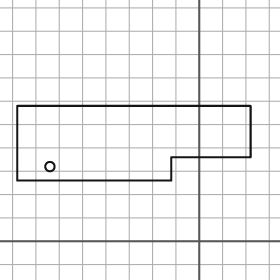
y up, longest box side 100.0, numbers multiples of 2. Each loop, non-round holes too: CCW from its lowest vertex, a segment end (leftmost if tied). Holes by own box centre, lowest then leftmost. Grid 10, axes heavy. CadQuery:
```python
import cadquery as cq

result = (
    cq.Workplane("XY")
    .moveTo(-78.0, 26.0)
    .lineTo(-12.0, 26.0)
    .lineTo(-12.0, 36.0)
    .lineTo(22.0, 36.0)
    .lineTo(22.0, 58.0)
    .lineTo(-78.0, 58.0)
    .close()
    .moveTo(-64.0, 32.0)
    .circle(2.0)
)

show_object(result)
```